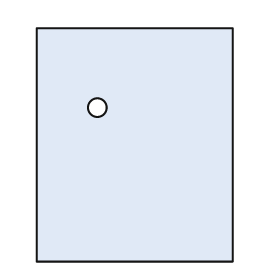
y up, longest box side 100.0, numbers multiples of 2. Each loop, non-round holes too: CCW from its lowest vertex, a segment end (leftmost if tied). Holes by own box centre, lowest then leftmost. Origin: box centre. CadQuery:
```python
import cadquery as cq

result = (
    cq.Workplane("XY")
    .moveTo(-42.0, -50.0)
    .lineTo(42.0, -50.0)
    .lineTo(42.0, 50.0)
    .lineTo(-42.0, 50.0)
    .close()
    .moveTo(-16.0, 16.0)
    .circle(4.0)
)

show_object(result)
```